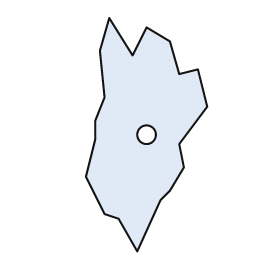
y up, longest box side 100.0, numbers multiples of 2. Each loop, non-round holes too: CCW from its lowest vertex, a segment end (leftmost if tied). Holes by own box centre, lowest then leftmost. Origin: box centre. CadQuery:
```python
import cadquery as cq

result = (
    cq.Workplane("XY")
    .moveTo(-4.0, -50.0)
    .lineTo(6.0, -28.0)
    .lineTo(10.0, -24.0)
    .lineTo(16.0, -14.0)
    .lineTo(14.0, -4.0)
    .lineTo(26.0, 12.0)
    .lineTo(22.0, 28.0)
    .lineTo(14.0, 26.0)
    .lineTo(10.0, 40.0)
    .lineTo(0.0, 46.0)
    .lineTo(-6.0, 34.0)
    .lineTo(-16.0, 50.0)
    .lineTo(-20.0, 36.0)
    .lineTo(-18.0, 16.0)
    .lineTo(-22.0, 6.0)
    .lineTo(-22.0, -2.0)
    .lineTo(-26.0, -18.0)
    .lineTo(-18.0, -34.0)
    .lineTo(-12.0, -36.0)
    .close()
    .moveTo(0.0, 0.0)
    .circle(4.0)
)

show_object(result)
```